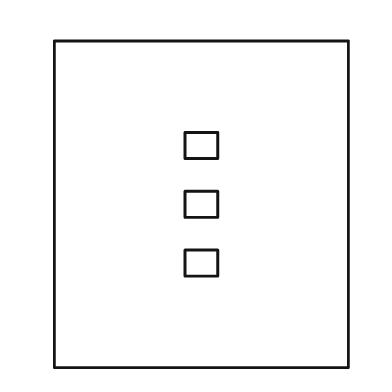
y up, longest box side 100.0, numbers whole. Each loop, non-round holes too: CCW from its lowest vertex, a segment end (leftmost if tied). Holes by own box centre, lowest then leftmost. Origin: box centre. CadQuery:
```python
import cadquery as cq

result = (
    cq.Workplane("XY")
    .moveTo(-45.0, -50.0)
    .lineTo(45.0, -50.0)
    .lineTo(45.0, 50.0)
    .lineTo(-45.0, 50.0)
    .close()
    .moveTo(-5.0, -22.0)
    .lineTo(5.0, -22.0)
    .lineTo(5.0, -14.0)
    .lineTo(-5.0, -14.0)
    .close()
    .moveTo(-5.0, -4.0)
    .lineTo(5.0, -4.0)
    .lineTo(5.0, 4.0)
    .lineTo(-5.0, 4.0)
    .close()
    .moveTo(-5.0, 14.0)
    .lineTo(5.0, 14.0)
    .lineTo(5.0, 22.0)
    .lineTo(-5.0, 22.0)
    .close()
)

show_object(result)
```